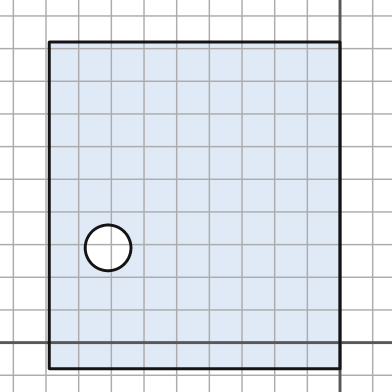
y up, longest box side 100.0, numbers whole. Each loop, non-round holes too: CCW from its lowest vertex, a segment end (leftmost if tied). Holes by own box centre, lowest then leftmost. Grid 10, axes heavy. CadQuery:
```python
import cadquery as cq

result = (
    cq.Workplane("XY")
    .moveTo(-89.0, -8.0)
    .lineTo(0.0, -8.0)
    .lineTo(0.0, 92.0)
    .lineTo(-89.0, 92.0)
    .close()
    .moveTo(-71.0, 29.0)
    .circle(7.0)
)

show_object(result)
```